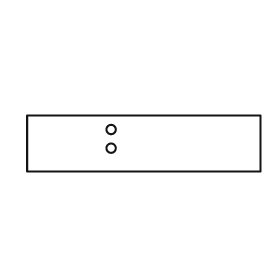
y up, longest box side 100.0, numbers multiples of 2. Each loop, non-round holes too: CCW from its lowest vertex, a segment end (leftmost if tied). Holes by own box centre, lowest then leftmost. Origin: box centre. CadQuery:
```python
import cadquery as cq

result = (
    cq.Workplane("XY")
    .moveTo(-50.0, -12.0)
    .lineTo(50.0, -12.0)
    .lineTo(50.0, 12.0)
    .lineTo(-50.0, 12.0)
    .close()
    .moveTo(-14.0, -2.0)
    .circle(2.0)
    .moveTo(-14.0, 6.0)
    .circle(2.0)
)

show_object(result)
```